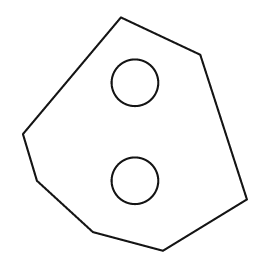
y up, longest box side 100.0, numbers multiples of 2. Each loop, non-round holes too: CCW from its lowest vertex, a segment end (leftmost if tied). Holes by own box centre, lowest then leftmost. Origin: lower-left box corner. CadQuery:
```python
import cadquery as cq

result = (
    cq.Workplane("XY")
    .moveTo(60.0, 0.0)
    .lineTo(96.0, 22.0)
    .lineTo(76.0, 84.0)
    .lineTo(42.0, 100.0)
    .lineTo(0.0, 50.0)
    .lineTo(6.0, 30.0)
    .lineTo(30.0, 8.0)
    .close()
    .moveTo(48.0, 30.0)
    .circle(10.0)
    .moveTo(48.0, 72.0)
    .circle(10.0)
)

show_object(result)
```